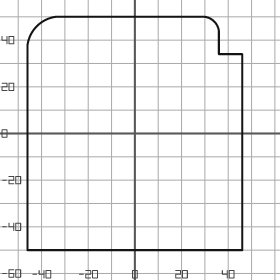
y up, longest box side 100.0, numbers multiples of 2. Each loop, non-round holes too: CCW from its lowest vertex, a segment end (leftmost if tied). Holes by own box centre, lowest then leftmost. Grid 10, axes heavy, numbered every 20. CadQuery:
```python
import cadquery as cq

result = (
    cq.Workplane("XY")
    .moveTo(-46.0, -50.0)
    .lineTo(46.0, -50.0)
    .lineTo(46.0, 34.0)
    .lineTo(36.0, 34.0)
    .lineTo(36.0, 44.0)
    .threePointArc((34.0, 48.0), (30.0, 50.0))
    .lineTo(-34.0, 50.0)
    .threePointArc((-42.0, 46.0), (-46.0, 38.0))
    .close()
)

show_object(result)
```